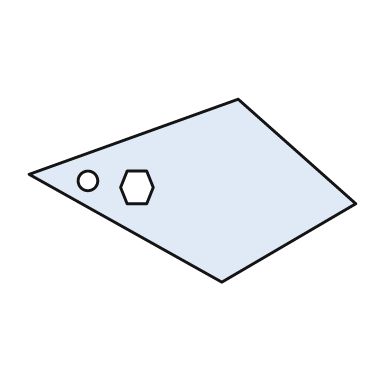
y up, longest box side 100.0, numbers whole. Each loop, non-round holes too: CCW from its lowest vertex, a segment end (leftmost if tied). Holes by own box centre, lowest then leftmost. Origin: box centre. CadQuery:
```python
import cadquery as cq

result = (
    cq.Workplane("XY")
    .moveTo(9.0, -28.0)
    .lineTo(50.0, -4.0)
    .lineTo(14.0, 28.0)
    .lineTo(-50.0, 5.0)
    .close()
    .moveTo(-20.0, -4.0)
    .lineTo(-14.0, -4.0)
    .lineTo(-12.0, 1.0)
    .lineTo(-14.0, 6.0)
    .lineTo(-20.0, 6.0)
    .lineTo(-22.0, 1.0)
    .close()
    .moveTo(-32.0, 3.0)
    .circle(3.0)
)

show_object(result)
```